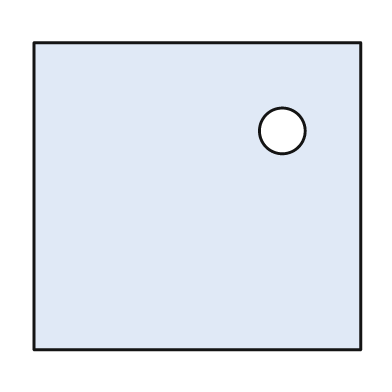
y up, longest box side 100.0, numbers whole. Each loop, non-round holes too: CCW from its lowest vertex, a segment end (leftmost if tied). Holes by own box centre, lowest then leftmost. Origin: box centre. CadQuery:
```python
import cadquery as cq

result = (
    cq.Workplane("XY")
    .moveTo(-50.0, -47.0)
    .lineTo(50.0, -47.0)
    .lineTo(50.0, 47.0)
    .lineTo(-50.0, 47.0)
    .close()
    .moveTo(26.0, 20.0)
    .circle(7.0)
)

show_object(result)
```